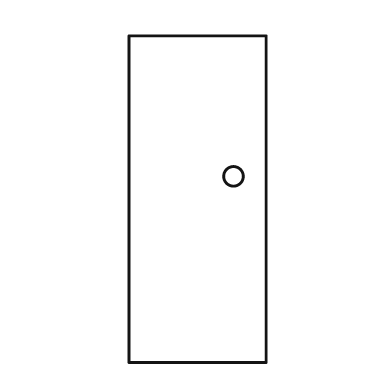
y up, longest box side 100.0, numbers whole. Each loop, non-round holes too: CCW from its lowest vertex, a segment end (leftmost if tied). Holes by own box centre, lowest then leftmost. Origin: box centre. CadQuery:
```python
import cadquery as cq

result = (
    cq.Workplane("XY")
    .moveTo(-21.0, -50.0)
    .lineTo(21.0, -50.0)
    .lineTo(21.0, 50.0)
    .lineTo(-21.0, 50.0)
    .close()
    .moveTo(11.0, 7.0)
    .circle(3.0)
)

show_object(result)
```